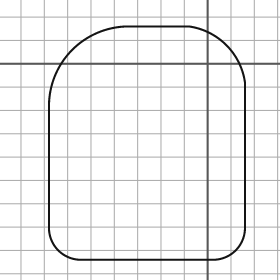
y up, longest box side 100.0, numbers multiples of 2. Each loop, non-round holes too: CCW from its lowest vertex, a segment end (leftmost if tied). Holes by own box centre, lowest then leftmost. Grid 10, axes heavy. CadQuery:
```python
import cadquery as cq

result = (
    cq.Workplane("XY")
    .moveTo(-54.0, -84.0)
    .lineTo(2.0, -84.0)
    .threePointArc((12.0, -80.0), (16.0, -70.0))
    .lineTo(16.0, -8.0)
    .threePointArc((8.0, 8.0), (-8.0, 16.0))
    .lineTo(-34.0, 16.0)
    .threePointArc((-58.0, 6.0), (-68.0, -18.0))
    .lineTo(-68.0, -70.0)
    .threePointArc((-64.0, -80.0), (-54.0, -84.0))
    .close()
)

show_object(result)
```